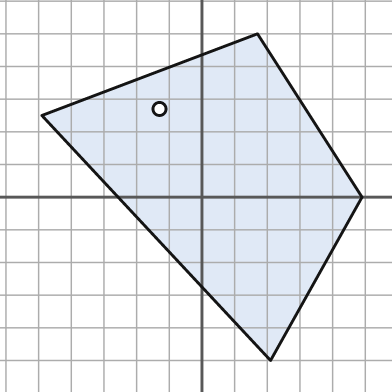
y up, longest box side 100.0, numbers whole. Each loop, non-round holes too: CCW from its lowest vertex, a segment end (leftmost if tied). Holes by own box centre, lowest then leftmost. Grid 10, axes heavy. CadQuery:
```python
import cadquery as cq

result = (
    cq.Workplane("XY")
    .moveTo(21.0, -50.0)
    .lineTo(49.0, 0.0)
    .lineTo(17.0, 50.0)
    .lineTo(-49.0, 25.0)
    .close()
    .moveTo(-13.0, 27.0)
    .circle(2.0)
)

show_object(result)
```